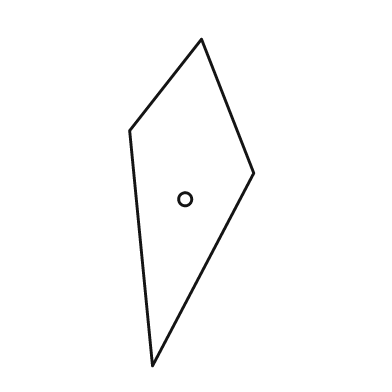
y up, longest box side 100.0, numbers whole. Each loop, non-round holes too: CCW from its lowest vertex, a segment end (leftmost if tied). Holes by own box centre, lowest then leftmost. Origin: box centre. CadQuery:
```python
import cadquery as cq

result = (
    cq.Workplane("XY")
    .moveTo(-12.0, -50.0)
    .lineTo(19.0, 9.0)
    .lineTo(3.0, 50.0)
    .lineTo(-19.0, 22.0)
    .close()
    .moveTo(-2.0, 1.0)
    .circle(2.0)
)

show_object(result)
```